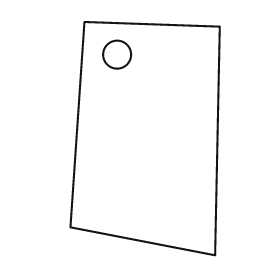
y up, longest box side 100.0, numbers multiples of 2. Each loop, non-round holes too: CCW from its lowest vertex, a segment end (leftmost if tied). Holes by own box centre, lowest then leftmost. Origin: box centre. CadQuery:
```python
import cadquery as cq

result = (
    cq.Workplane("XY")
    .moveTo(30.0, -50.0)
    .lineTo(32.0, 48.0)
    .lineTo(-26.0, 50.0)
    .lineTo(-32.0, -38.0)
    .close()
    .moveTo(-12.0, 36.0)
    .circle(6.0)
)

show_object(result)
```